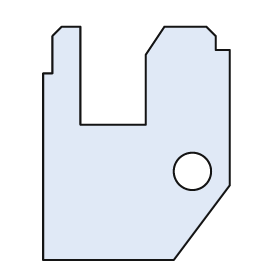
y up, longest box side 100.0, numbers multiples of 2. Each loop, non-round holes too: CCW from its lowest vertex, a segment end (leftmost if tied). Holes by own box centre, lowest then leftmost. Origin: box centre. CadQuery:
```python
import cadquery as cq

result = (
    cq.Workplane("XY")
    .moveTo(-40.0, -50.0)
    .lineTo(16.0, -50.0)
    .lineTo(40.0, -18.0)
    .lineTo(40.0, 40.0)
    .lineTo(34.0, 40.0)
    .lineTo(34.0, 46.0)
    .lineTo(30.0, 50.0)
    .lineTo(12.0, 50.0)
    .lineTo(4.0, 38.0)
    .lineTo(4.0, 8.0)
    .lineTo(-24.0, 8.0)
    .lineTo(-24.0, 50.0)
    .lineTo(-32.0, 50.0)
    .lineTo(-36.0, 46.0)
    .lineTo(-36.0, 30.0)
    .lineTo(-40.0, 30.0)
    .close()
    .moveTo(24.0, -12.0)
    .circle(8.0)
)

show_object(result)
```